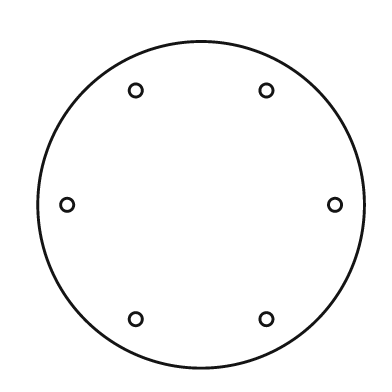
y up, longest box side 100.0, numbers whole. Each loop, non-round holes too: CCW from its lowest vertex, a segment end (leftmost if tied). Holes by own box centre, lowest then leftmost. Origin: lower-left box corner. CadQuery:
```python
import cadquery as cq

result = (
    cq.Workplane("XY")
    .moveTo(50.0, 50.0)
    .circle(50.0)
    .moveTo(30.0, 15.0)
    .circle(2.0)
    .moveTo(70.0, 15.0)
    .circle(2.0)
    .moveTo(9.0, 50.0)
    .circle(2.0)
    .moveTo(91.0, 50.0)
    .circle(2.0)
    .moveTo(30.0, 85.0)
    .circle(2.0)
    .moveTo(70.0, 85.0)
    .circle(2.0)
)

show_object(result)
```